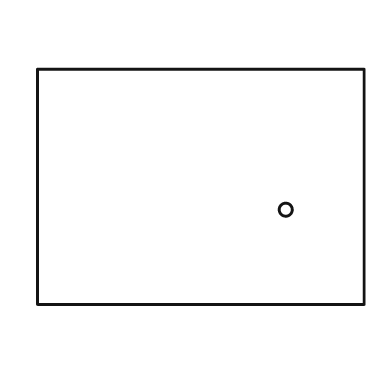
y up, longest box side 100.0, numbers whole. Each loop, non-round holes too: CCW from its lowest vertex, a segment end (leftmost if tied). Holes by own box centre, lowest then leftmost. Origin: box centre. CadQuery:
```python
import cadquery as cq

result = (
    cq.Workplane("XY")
    .moveTo(-50.0, -36.0)
    .lineTo(50.0, -36.0)
    .lineTo(50.0, 36.0)
    .lineTo(-50.0, 36.0)
    .close()
    .moveTo(26.0, -7.0)
    .circle(2.0)
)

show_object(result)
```